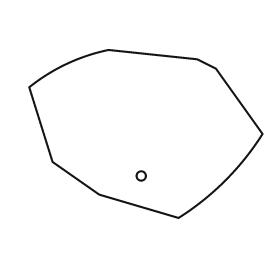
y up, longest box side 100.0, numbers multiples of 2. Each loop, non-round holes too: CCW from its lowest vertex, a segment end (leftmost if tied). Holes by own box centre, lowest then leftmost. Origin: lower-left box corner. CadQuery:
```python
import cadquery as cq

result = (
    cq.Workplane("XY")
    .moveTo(64.0, 0.0)
    .threePointArc((84.0, 16.0), (100.0, 36.0))
    .lineTo(80.0, 64.0)
    .lineTo(72.0, 68.0)
    .lineTo(34.0, 72.0)
    .threePointArc((16.0, 66.0), (0.0, 56.0))
    .lineTo(10.0, 24.0)
    .lineTo(30.0, 10.0)
    .close()
    .moveTo(48.0, 18.0)
    .circle(2.0)
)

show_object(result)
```